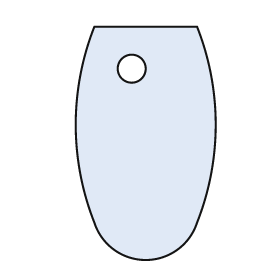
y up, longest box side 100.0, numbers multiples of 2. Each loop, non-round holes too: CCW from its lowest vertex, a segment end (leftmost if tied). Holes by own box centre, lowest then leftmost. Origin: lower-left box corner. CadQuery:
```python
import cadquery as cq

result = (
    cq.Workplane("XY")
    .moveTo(8.0, 16.0)
    .threePointArc((30.0, 0.0), (52.0, 16.0))
    .threePointArc((60.0, 58.0), (52.0, 100.0))
    .lineTo(8.0, 100.0)
    .threePointArc((0.0, 58.0), (8.0, 16.0))
    .close()
    .moveTo(24.0, 82.0)
    .circle(6.0)
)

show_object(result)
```